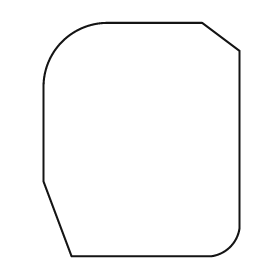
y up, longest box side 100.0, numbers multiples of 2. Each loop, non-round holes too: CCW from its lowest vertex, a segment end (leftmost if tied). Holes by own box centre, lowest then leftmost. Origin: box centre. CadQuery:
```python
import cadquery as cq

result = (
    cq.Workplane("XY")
    .moveTo(-30.0, -50.0)
    .lineTo(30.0, -50.0)
    .threePointArc((38.0, -46.0), (42.0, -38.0))
    .lineTo(42.0, 38.0)
    .lineTo(26.0, 50.0)
    .lineTo(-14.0, 50.0)
    .threePointArc((-34.0, 42.0), (-42.0, 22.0))
    .lineTo(-42.0, -18.0)
    .close()
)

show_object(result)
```